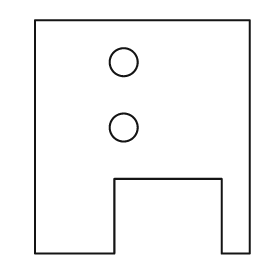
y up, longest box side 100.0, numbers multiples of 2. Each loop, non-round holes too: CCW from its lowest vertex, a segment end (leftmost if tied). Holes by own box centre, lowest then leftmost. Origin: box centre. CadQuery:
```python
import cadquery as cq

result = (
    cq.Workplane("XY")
    .moveTo(-46.0, -50.0)
    .lineTo(-12.0, -50.0)
    .lineTo(-12.0, -18.0)
    .lineTo(34.0, -18.0)
    .lineTo(34.0, -50.0)
    .lineTo(46.0, -50.0)
    .lineTo(46.0, 50.0)
    .lineTo(-46.0, 50.0)
    .close()
    .moveTo(-8.0, 4.0)
    .circle(6.0)
    .moveTo(-8.0, 32.0)
    .circle(6.0)
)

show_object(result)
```